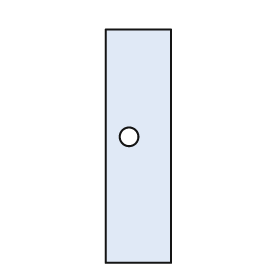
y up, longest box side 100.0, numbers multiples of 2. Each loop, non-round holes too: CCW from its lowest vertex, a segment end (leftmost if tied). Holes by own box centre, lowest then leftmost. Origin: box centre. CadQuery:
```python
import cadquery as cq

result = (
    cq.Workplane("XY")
    .moveTo(-14.0, -50.0)
    .lineTo(14.0, -50.0)
    .lineTo(14.0, 50.0)
    .lineTo(-14.0, 50.0)
    .close()
    .moveTo(-4.0, 4.0)
    .circle(4.0)
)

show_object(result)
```